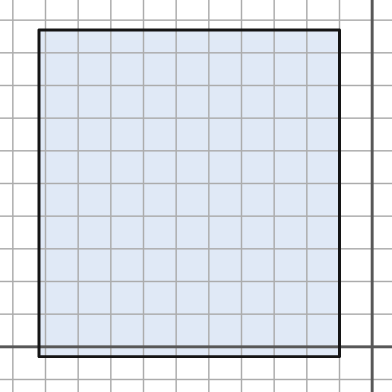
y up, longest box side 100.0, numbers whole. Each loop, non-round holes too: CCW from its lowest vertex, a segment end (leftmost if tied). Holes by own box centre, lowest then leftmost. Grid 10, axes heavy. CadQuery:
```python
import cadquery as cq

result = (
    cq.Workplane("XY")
    .moveTo(-102.0, -3.0)
    .lineTo(-10.0, -3.0)
    .lineTo(-10.0, 97.0)
    .lineTo(-102.0, 97.0)
    .close()
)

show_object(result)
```